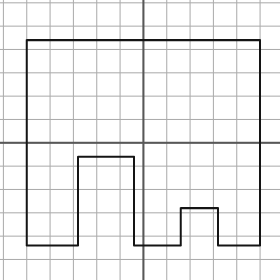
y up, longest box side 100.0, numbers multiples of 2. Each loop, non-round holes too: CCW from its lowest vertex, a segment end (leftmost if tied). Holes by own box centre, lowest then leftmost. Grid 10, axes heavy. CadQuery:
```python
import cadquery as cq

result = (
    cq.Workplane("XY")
    .moveTo(-50.0, -44.0)
    .lineTo(-28.0, -44.0)
    .lineTo(-28.0, -6.0)
    .lineTo(-4.0, -6.0)
    .lineTo(-4.0, -44.0)
    .lineTo(16.0, -44.0)
    .lineTo(16.0, -28.0)
    .lineTo(32.0, -28.0)
    .lineTo(32.0, -44.0)
    .lineTo(50.0, -44.0)
    .lineTo(50.0, 44.0)
    .lineTo(-50.0, 44.0)
    .close()
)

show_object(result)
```